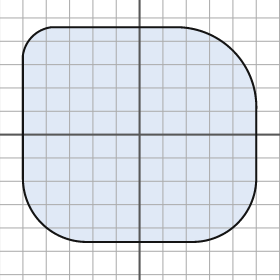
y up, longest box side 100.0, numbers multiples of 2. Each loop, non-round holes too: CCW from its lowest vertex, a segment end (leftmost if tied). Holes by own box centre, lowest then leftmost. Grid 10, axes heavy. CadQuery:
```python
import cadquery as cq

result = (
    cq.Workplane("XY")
    .moveTo(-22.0, -46.0)
    .lineTo(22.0, -46.0)
    .threePointArc((42.0, -38.0), (50.0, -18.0))
    .lineTo(50.0, 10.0)
    .threePointArc((40.0, 36.0), (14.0, 46.0))
    .lineTo(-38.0, 46.0)
    .threePointArc((-46.0, 42.0), (-50.0, 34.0))
    .lineTo(-50.0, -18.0)
    .threePointArc((-42.0, -38.0), (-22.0, -46.0))
    .close()
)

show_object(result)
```